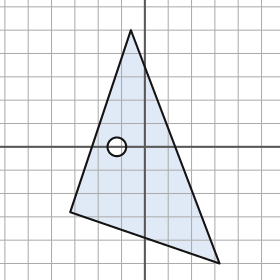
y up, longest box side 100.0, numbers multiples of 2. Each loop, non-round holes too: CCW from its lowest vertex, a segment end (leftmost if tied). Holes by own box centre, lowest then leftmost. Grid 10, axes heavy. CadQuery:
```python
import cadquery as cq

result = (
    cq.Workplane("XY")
    .moveTo(32.0, -50.0)
    .lineTo(-6.0, 50.0)
    .lineTo(-32.0, -28.0)
    .close()
    .moveTo(-12.0, 0.0)
    .circle(4.0)
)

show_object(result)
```